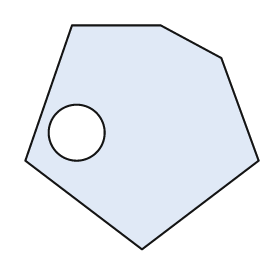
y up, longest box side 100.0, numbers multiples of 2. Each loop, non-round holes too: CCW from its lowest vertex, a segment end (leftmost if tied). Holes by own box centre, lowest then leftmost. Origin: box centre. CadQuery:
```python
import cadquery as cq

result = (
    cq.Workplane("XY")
    .moveTo(0.0, -48.0)
    .lineTo(50.0, -10.0)
    .lineTo(34.0, 34.0)
    .lineTo(8.0, 48.0)
    .lineTo(-30.0, 48.0)
    .lineTo(-50.0, -10.0)
    .close()
    .moveTo(-28.0, 2.0)
    .circle(12.0)
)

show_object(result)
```